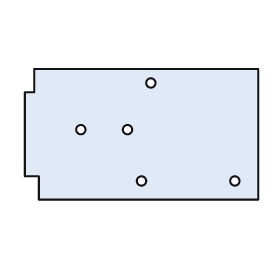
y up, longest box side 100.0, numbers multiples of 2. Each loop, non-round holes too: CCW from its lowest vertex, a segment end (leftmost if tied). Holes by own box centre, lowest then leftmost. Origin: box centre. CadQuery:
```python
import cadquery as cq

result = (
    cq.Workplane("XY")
    .moveTo(-44.0, -28.0)
    .lineTo(50.0, -28.0)
    .lineTo(50.0, 28.0)
    .lineTo(-46.0, 28.0)
    .lineTo(-46.0, 18.0)
    .lineTo(-50.0, 18.0)
    .lineTo(-50.0, -18.0)
    .lineTo(-44.0, -18.0)
    .close()
    .moveTo(0.0, -20.0)
    .circle(2.0)
    .moveTo(40.0, -20.0)
    .circle(2.0)
    .moveTo(-26.0, 2.0)
    .circle(2.0)
    .moveTo(-6.0, 2.0)
    .circle(2.0)
    .moveTo(4.0, 22.0)
    .circle(2.0)
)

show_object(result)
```